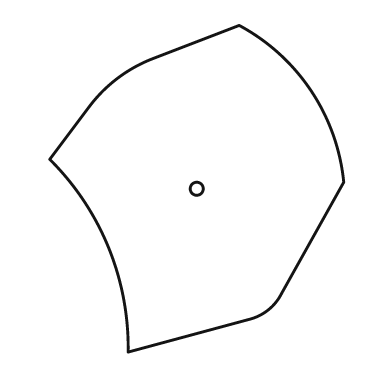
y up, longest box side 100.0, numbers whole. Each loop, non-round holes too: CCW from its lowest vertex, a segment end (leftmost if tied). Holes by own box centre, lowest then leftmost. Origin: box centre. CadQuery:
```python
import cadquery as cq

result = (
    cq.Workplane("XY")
    .moveTo(-21.0, -50.0)
    .lineTo(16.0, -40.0)
    .threePointArc((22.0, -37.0), (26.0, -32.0))
    .lineTo(45.0, 2.0)
    .threePointArc((35.0, 30.0), (13.0, 50.0))
    .lineTo(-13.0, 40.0)
    .threePointArc((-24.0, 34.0), (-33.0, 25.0))
    .lineTo(-45.0, 9.0)
    .threePointArc((-27.0, -18.0), (-21.0, -50.0))
    .close()
    .moveTo(0.0, 0.0)
    .circle(2.0)
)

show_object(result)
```